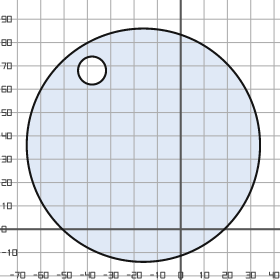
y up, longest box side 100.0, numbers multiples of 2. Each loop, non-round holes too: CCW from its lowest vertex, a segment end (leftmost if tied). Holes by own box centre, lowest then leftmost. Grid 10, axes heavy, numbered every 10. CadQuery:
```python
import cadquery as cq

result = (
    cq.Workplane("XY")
    .moveTo(-16.0, 36.0)
    .circle(50.0)
    .moveTo(-38.0, 68.0)
    .circle(6.0)
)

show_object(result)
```